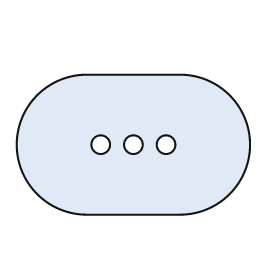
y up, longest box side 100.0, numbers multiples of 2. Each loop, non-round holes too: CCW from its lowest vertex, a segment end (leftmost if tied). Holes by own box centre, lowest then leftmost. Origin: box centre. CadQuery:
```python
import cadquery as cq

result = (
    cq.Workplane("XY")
    .moveTo(-20.0, -30.0)
    .lineTo(20.0, -30.0)
    .threePointArc((50.0, 0.0), (20.0, 30.0))
    .lineTo(-20.0, 30.0)
    .threePointArc((-50.0, 0.0), (-20.0, -30.0))
    .close()
    .moveTo(-14.0, 0.0)
    .circle(4.0)
    .moveTo(0.0, 0.0)
    .circle(4.0)
    .moveTo(14.0, 0.0)
    .circle(4.0)
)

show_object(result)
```